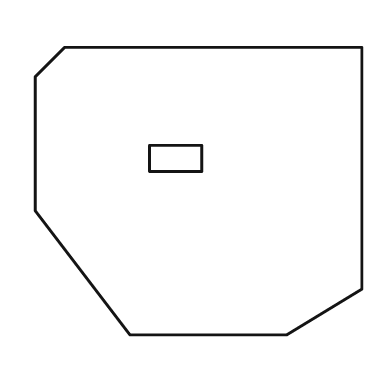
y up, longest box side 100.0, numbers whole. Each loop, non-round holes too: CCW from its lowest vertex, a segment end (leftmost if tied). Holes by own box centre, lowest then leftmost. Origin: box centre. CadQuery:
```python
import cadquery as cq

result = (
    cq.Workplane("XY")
    .moveTo(-21.0, -44.0)
    .lineTo(27.0, -44.0)
    .lineTo(50.0, -30.0)
    .lineTo(50.0, 44.0)
    .lineTo(-41.0, 44.0)
    .lineTo(-50.0, 35.0)
    .lineTo(-50.0, -6.0)
    .close()
    .moveTo(-15.0, 6.0)
    .lineTo(1.0, 6.0)
    .lineTo(1.0, 14.0)
    .lineTo(-15.0, 14.0)
    .close()
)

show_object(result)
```